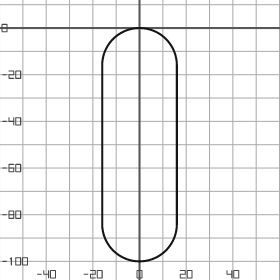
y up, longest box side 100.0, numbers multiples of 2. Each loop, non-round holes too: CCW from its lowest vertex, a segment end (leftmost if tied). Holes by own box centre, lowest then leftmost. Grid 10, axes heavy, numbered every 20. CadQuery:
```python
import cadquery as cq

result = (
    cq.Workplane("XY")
    .moveTo(-16.0, -84.0)
    .threePointArc((0.0, -100.0), (16.0, -84.0))
    .lineTo(16.0, -16.0)
    .threePointArc((0.0, 0.0), (-16.0, -16.0))
    .close()
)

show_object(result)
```